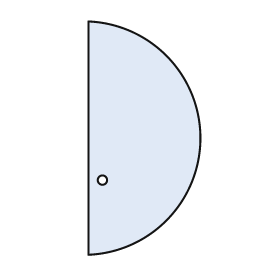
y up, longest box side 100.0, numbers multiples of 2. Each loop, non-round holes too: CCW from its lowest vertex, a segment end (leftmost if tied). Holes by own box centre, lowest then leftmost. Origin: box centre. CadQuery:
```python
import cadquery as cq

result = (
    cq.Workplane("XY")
    .moveTo(-24.0, -50.0)
    .threePointArc((24.0, 0.0), (-24.0, 50.0))
    .close()
    .moveTo(-18.0, -18.0)
    .circle(2.0)
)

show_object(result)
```